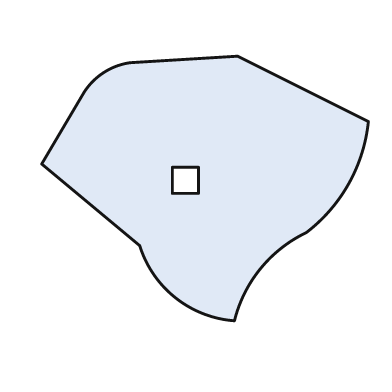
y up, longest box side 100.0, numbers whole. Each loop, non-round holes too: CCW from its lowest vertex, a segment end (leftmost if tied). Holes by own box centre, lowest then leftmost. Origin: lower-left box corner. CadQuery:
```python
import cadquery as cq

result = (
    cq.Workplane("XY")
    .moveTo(59.0, 0.0)
    .threePointArc((67.0, 16.0), (81.0, 27.0))
    .threePointArc((94.0, 42.0), (100.0, 61.0))
    .lineTo(60.0, 81.0)
    .lineTo(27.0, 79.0)
    .threePointArc((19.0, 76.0), (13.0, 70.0))
    .lineTo(0.0, 48.0)
    .lineTo(30.0, 23.0)
    .threePointArc((41.0, 7.0), (59.0, 0.0))
    .close()
    .moveTo(40.0, 39.0)
    .lineTo(48.0, 39.0)
    .lineTo(48.0, 47.0)
    .lineTo(40.0, 47.0)
    .close()
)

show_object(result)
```